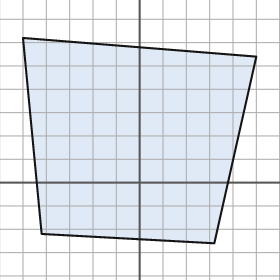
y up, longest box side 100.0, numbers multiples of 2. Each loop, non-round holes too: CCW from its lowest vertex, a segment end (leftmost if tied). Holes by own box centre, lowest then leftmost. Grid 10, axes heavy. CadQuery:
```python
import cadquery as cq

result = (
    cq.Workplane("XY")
    .moveTo(32.0, -26.0)
    .lineTo(50.0, 54.0)
    .lineTo(-50.0, 62.0)
    .lineTo(-42.0, -22.0)
    .close()
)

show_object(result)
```